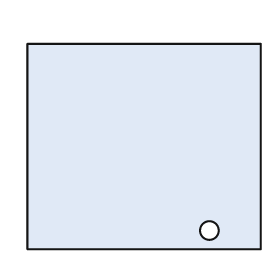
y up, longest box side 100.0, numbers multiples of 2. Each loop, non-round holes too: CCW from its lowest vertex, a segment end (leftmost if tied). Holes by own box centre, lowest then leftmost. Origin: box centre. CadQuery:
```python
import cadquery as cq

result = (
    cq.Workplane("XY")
    .moveTo(-50.0, -44.0)
    .lineTo(50.0, -44.0)
    .lineTo(50.0, 44.0)
    .lineTo(-50.0, 44.0)
    .close()
    .moveTo(28.0, -36.0)
    .circle(4.0)
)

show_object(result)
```